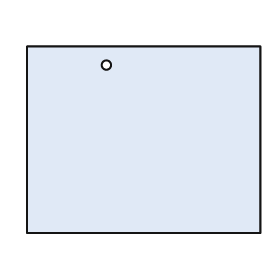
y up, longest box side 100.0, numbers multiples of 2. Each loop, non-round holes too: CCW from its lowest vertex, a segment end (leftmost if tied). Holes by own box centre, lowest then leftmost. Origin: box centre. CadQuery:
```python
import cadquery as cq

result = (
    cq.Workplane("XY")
    .moveTo(-50.0, -40.0)
    .lineTo(50.0, -40.0)
    .lineTo(50.0, 40.0)
    .lineTo(-50.0, 40.0)
    .close()
    .moveTo(-16.0, 32.0)
    .circle(2.0)
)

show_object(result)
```